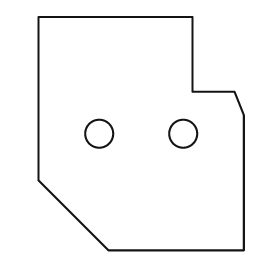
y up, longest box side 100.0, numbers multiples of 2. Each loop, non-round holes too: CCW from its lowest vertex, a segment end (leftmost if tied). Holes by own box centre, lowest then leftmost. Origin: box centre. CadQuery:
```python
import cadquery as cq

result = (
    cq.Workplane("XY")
    .moveTo(-14.0, -50.0)
    .lineTo(44.0, -50.0)
    .lineTo(44.0, 8.0)
    .lineTo(40.0, 18.0)
    .lineTo(22.0, 18.0)
    .lineTo(22.0, 50.0)
    .lineTo(-44.0, 50.0)
    .lineTo(-44.0, -20.0)
    .close()
    .moveTo(-18.0, 0.0)
    .circle(6.0)
    .moveTo(18.0, 0.0)
    .circle(6.0)
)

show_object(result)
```